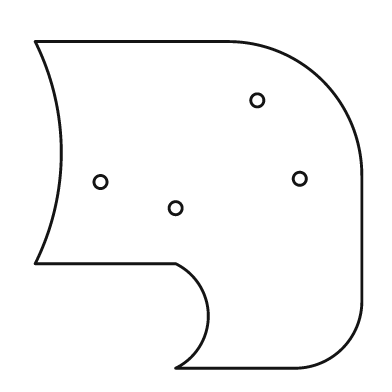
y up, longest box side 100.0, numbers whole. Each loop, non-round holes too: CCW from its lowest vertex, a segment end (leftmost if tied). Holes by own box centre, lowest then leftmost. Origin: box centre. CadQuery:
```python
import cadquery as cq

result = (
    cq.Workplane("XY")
    .moveTo(-7.0, -50.0)
    .lineTo(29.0, -50.0)
    .threePointArc((44.0, -44.0), (50.0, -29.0))
    .lineTo(50.0, 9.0)
    .threePointArc((38.0, 38.0), (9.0, 50.0))
    .lineTo(-50.0, 50.0)
    .threePointArc((-42.0, 16.0), (-50.0, -18.0))
    .lineTo(-7.0, -18.0)
    .threePointArc((3.0, -34.0), (-7.0, -50.0))
    .close()
    .moveTo(-7.0, -1.0)
    .circle(2.0)
    .moveTo(-30.0, 7.0)
    .circle(2.0)
    .moveTo(31.0, 8.0)
    .circle(2.0)
    .moveTo(18.0, 32.0)
    .circle(2.0)
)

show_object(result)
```